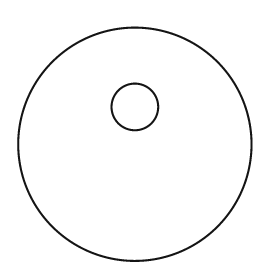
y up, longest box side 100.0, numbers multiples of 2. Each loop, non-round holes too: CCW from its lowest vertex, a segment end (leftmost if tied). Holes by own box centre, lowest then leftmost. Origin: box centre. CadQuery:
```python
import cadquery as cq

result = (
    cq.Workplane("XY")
    .moveTo(0.0, 0.0)
    .circle(50.0)
    .moveTo(0.0, 16.0)
    .circle(10.0)
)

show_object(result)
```